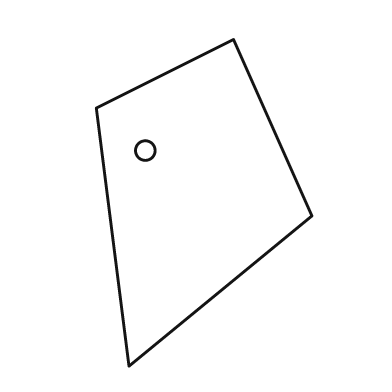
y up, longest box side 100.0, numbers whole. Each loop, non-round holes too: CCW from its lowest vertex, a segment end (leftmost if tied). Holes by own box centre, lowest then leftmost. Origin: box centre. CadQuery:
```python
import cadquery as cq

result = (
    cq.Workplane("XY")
    .moveTo(-23.0, -50.0)
    .lineTo(33.0, -4.0)
    .lineTo(9.0, 50.0)
    .lineTo(-33.0, 29.0)
    .close()
    .moveTo(-18.0, 16.0)
    .circle(3.0)
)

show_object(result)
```